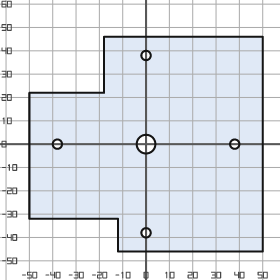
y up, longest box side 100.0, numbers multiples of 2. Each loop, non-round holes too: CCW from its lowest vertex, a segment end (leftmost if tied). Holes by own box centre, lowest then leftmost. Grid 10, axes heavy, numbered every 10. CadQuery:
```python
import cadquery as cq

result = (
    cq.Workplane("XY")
    .moveTo(-12.0, -46.0)
    .lineTo(50.0, -46.0)
    .lineTo(50.0, 46.0)
    .lineTo(-18.0, 46.0)
    .lineTo(-18.0, 22.0)
    .lineTo(-50.0, 22.0)
    .lineTo(-50.0, -32.0)
    .lineTo(-12.0, -32.0)
    .close()
    .moveTo(0.0, -38.0)
    .circle(2.0)
    .moveTo(-38.0, 0.0)
    .circle(2.0)
    .moveTo(0.0, 0.0)
    .circle(4.0)
    .moveTo(38.0, 0.0)
    .circle(2.0)
    .moveTo(0.0, 38.0)
    .circle(2.0)
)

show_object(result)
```